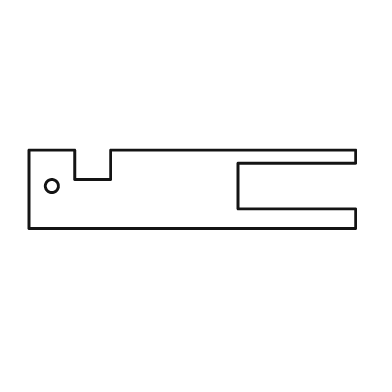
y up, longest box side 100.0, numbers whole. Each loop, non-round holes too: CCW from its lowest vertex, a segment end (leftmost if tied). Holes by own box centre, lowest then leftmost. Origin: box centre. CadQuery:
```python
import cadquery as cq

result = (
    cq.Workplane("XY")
    .moveTo(-50.0, -12.0)
    .lineTo(50.0, -12.0)
    .lineTo(50.0, -6.0)
    .lineTo(14.0, -6.0)
    .lineTo(14.0, 8.0)
    .lineTo(50.0, 8.0)
    .lineTo(50.0, 12.0)
    .lineTo(-25.0, 12.0)
    .lineTo(-25.0, 3.0)
    .lineTo(-36.0, 3.0)
    .lineTo(-36.0, 12.0)
    .lineTo(-50.0, 12.0)
    .close()
    .moveTo(-43.0, 1.0)
    .circle(2.0)
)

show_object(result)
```